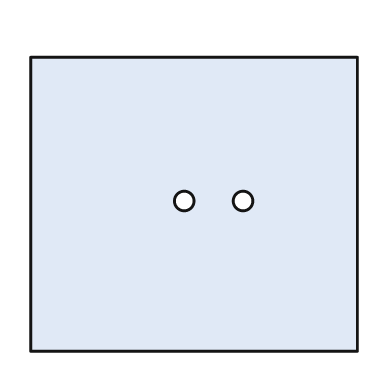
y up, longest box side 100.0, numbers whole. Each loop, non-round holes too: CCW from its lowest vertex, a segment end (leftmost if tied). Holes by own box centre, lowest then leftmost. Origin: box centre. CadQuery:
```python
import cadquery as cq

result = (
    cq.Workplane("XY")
    .moveTo(-50.0, -45.0)
    .lineTo(50.0, -45.0)
    .lineTo(50.0, 45.0)
    .lineTo(-50.0, 45.0)
    .close()
    .moveTo(-3.0, 1.0)
    .circle(3.0)
    .moveTo(15.0, 1.0)
    .circle(3.0)
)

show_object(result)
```